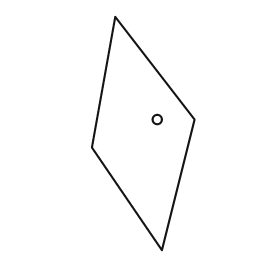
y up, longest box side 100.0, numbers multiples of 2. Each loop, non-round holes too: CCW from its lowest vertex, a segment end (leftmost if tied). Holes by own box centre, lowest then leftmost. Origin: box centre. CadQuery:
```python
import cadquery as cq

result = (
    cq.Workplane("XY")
    .moveTo(8.0, -50.0)
    .lineTo(22.0, 6.0)
    .lineTo(-12.0, 50.0)
    .lineTo(-22.0, -6.0)
    .close()
    .moveTo(6.0, 6.0)
    .circle(2.0)
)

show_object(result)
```